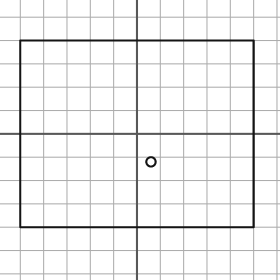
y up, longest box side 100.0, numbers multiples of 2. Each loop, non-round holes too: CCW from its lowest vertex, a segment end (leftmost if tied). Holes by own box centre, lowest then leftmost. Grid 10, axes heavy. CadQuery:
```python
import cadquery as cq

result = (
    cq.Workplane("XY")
    .moveTo(-50.0, -40.0)
    .lineTo(50.0, -40.0)
    .lineTo(50.0, 40.0)
    .lineTo(-50.0, 40.0)
    .close()
    .moveTo(6.0, -12.0)
    .circle(2.0)
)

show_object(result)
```